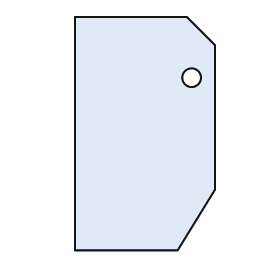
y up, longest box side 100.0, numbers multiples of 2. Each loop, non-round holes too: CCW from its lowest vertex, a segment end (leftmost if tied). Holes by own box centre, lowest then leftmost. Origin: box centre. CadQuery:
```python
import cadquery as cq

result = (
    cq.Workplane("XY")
    .moveTo(-30.0, -50.0)
    .lineTo(14.0, -50.0)
    .lineTo(30.0, -24.0)
    .lineTo(30.0, 38.0)
    .lineTo(18.0, 50.0)
    .lineTo(-30.0, 50.0)
    .close()
    .moveTo(20.0, 24.0)
    .circle(4.0)
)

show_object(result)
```